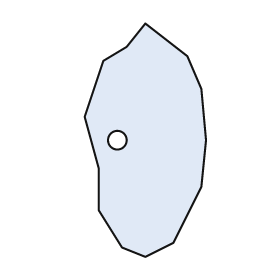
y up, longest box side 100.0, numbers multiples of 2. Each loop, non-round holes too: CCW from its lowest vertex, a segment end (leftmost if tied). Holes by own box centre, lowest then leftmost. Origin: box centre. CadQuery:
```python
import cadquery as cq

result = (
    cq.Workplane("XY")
    .moveTo(0.0, -50.0)
    .lineTo(12.0, -44.0)
    .lineTo(24.0, -20.0)
    .lineTo(26.0, 0.0)
    .lineTo(24.0, 22.0)
    .lineTo(18.0, 36.0)
    .lineTo(0.0, 50.0)
    .lineTo(-8.0, 40.0)
    .lineTo(-18.0, 34.0)
    .lineTo(-26.0, 10.0)
    .lineTo(-20.0, -12.0)
    .lineTo(-20.0, -30.0)
    .lineTo(-10.0, -46.0)
    .close()
    .moveTo(-12.0, 0.0)
    .circle(4.0)
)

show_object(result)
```